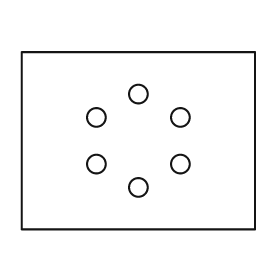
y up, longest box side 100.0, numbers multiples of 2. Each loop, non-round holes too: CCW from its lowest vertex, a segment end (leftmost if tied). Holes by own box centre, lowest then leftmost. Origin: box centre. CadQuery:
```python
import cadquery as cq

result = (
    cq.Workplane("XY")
    .moveTo(-50.0, -38.0)
    .lineTo(50.0, -38.0)
    .lineTo(50.0, 38.0)
    .lineTo(-50.0, 38.0)
    .close()
    .moveTo(0.0, -20.0)
    .circle(4.0)
    .moveTo(-18.0, -10.0)
    .circle(4.0)
    .moveTo(18.0, -10.0)
    .circle(4.0)
    .moveTo(-18.0, 10.0)
    .circle(4.0)
    .moveTo(18.0, 10.0)
    .circle(4.0)
    .moveTo(0.0, 20.0)
    .circle(4.0)
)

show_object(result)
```